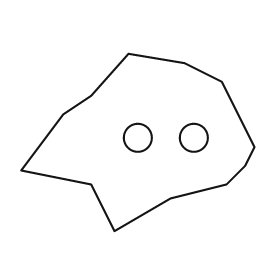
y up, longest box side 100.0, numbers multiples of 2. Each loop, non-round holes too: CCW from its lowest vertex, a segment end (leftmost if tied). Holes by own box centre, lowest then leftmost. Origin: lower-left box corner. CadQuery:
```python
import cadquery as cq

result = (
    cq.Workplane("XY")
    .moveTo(40.0, 0.0)
    .lineTo(64.0, 14.0)
    .lineTo(88.0, 20.0)
    .lineTo(96.0, 28.0)
    .lineTo(100.0, 36.0)
    .lineTo(86.0, 64.0)
    .lineTo(70.0, 72.0)
    .lineTo(46.0, 76.0)
    .lineTo(30.0, 58.0)
    .lineTo(18.0, 50.0)
    .lineTo(0.0, 26.0)
    .lineTo(30.0, 20.0)
    .close()
    .moveTo(50.0, 40.0)
    .circle(6.0)
    .moveTo(74.0, 40.0)
    .circle(6.0)
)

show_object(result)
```